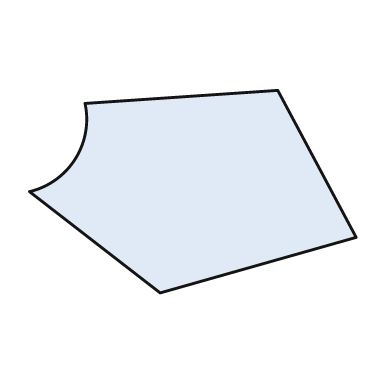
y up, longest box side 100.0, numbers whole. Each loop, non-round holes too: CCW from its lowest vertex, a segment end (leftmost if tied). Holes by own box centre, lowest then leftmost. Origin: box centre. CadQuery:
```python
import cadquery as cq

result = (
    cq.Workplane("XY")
    .moveTo(-10.0, -31.0)
    .lineTo(50.0, -14.0)
    .lineTo(26.0, 31.0)
    .lineTo(-33.0, 27.0)
    .threePointArc((-36.0, 10.0), (-50.0, 0.0))
    .close()
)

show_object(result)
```